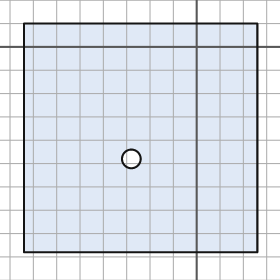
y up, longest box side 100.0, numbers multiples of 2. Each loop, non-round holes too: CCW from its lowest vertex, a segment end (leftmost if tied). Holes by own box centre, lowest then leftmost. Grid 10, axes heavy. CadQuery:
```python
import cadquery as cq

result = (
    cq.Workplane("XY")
    .moveTo(-74.0, -88.0)
    .lineTo(26.0, -88.0)
    .lineTo(26.0, 10.0)
    .lineTo(-74.0, 10.0)
    .close()
    .moveTo(-28.0, -48.0)
    .circle(4.0)
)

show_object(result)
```